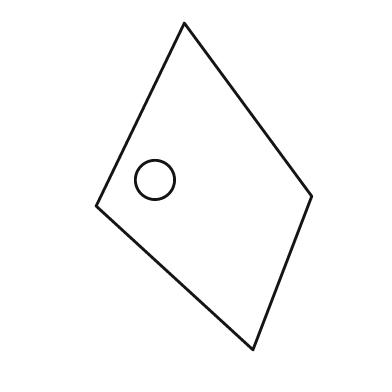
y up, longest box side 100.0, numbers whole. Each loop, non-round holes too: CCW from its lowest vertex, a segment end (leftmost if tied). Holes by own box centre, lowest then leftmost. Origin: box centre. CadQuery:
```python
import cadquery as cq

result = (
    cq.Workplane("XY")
    .moveTo(15.0, -50.0)
    .lineTo(33.0, -3.0)
    .lineTo(-6.0, 50.0)
    .lineTo(-33.0, -6.0)
    .close()
    .moveTo(-15.0, 2.0)
    .circle(6.0)
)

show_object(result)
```